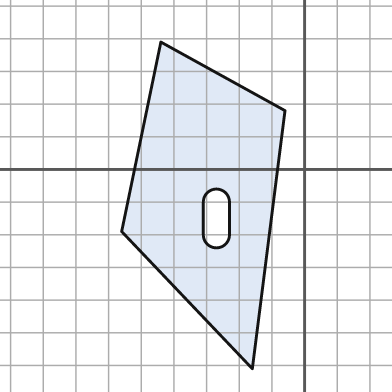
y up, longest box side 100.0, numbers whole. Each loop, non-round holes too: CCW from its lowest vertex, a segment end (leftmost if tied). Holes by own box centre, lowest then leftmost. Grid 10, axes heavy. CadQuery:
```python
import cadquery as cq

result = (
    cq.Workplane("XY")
    .moveTo(-16.0, -61.0)
    .lineTo(-6.0, 18.0)
    .lineTo(-44.0, 39.0)
    .lineTo(-56.0, -19.0)
    .close()
    .moveTo(-31.0, -20.0)
    .threePointArc((-27.0, -24.0), (-23.0, -20.0))
    .lineTo(-23.0, -10.0)
    .threePointArc((-27.0, -6.0), (-31.0, -10.0))
    .close()
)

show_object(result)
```